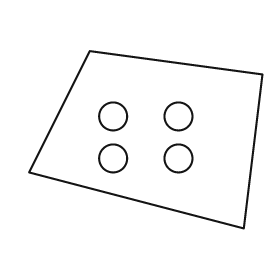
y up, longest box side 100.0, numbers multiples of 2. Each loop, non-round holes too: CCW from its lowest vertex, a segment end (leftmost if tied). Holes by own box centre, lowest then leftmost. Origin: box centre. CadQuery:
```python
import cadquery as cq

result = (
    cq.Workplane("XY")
    .moveTo(42.0, -38.0)
    .lineTo(50.0, 28.0)
    .lineTo(-24.0, 38.0)
    .lineTo(-50.0, -14.0)
    .close()
    .moveTo(-14.0, -8.0)
    .circle(6.0)
    .moveTo(14.0, -8.0)
    .circle(6.0)
    .moveTo(-14.0, 10.0)
    .circle(6.0)
    .moveTo(14.0, 10.0)
    .circle(6.0)
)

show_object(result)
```